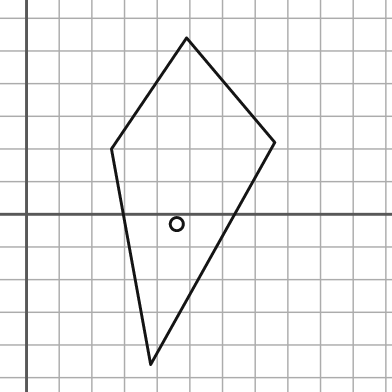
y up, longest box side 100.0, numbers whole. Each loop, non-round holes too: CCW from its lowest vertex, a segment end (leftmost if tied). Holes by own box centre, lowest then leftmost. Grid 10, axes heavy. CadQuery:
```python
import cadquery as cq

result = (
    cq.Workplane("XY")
    .moveTo(38.0, -46.0)
    .lineTo(76.0, 22.0)
    .lineTo(49.0, 54.0)
    .lineTo(26.0, 20.0)
    .close()
    .moveTo(46.0, -3.0)
    .circle(2.0)
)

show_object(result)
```